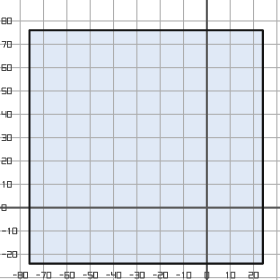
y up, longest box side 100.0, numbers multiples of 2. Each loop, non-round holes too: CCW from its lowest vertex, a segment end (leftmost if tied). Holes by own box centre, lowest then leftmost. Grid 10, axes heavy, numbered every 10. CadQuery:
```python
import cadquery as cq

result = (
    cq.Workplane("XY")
    .moveTo(-76.0, -24.0)
    .lineTo(24.0, -24.0)
    .lineTo(24.0, 76.0)
    .lineTo(-76.0, 76.0)
    .close()
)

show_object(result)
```